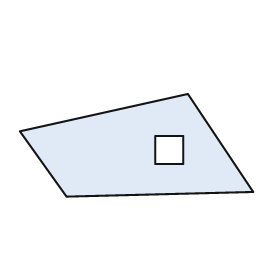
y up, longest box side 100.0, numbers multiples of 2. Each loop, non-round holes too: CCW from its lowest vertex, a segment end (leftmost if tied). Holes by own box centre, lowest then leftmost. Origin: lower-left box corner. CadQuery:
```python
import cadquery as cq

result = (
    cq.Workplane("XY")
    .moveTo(20.0, 0.0)
    .lineTo(100.0, 2.0)
    .lineTo(72.0, 44.0)
    .lineTo(0.0, 28.0)
    .close()
    .moveTo(58.0, 14.0)
    .lineTo(70.0, 14.0)
    .lineTo(70.0, 26.0)
    .lineTo(58.0, 26.0)
    .close()
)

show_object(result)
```